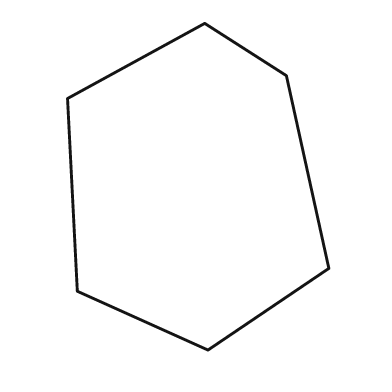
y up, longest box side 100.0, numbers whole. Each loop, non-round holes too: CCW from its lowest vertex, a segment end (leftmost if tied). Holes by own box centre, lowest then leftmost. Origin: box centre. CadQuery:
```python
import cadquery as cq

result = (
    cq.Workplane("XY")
    .moveTo(3.0, -50.0)
    .lineTo(40.0, -25.0)
    .lineTo(27.0, 34.0)
    .lineTo(2.0, 50.0)
    .lineTo(-40.0, 27.0)
    .lineTo(-37.0, -32.0)
    .close()
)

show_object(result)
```